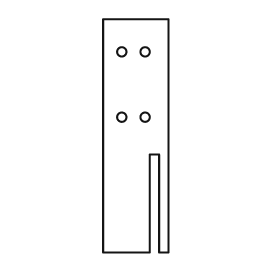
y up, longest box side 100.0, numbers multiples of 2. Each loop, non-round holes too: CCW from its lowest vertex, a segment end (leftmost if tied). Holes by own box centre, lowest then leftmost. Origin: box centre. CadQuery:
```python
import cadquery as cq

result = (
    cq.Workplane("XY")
    .moveTo(-14.0, -50.0)
    .lineTo(6.0, -50.0)
    .lineTo(6.0, -8.0)
    .lineTo(10.0, -8.0)
    .lineTo(10.0, -50.0)
    .lineTo(14.0, -50.0)
    .lineTo(14.0, 50.0)
    .lineTo(-14.0, 50.0)
    .close()
    .moveTo(-6.0, 8.0)
    .circle(2.0)
    .moveTo(4.0, 8.0)
    .circle(2.0)
    .moveTo(-6.0, 36.0)
    .circle(2.0)
    .moveTo(4.0, 36.0)
    .circle(2.0)
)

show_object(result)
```